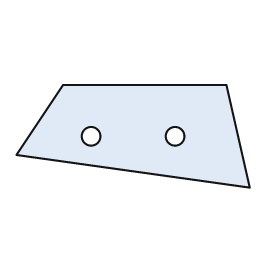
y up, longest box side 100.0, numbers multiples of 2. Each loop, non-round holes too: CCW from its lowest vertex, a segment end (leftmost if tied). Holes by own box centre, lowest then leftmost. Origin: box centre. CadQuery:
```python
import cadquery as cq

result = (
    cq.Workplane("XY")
    .moveTo(50.0, -22.0)
    .lineTo(40.0, 22.0)
    .lineTo(-30.0, 22.0)
    .lineTo(-50.0, -8.0)
    .close()
    .moveTo(-18.0, 0.0)
    .circle(4.0)
    .moveTo(18.0, 0.0)
    .circle(4.0)
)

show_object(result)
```